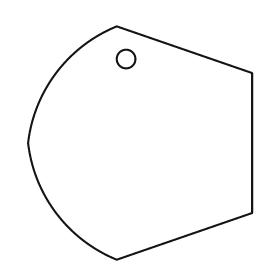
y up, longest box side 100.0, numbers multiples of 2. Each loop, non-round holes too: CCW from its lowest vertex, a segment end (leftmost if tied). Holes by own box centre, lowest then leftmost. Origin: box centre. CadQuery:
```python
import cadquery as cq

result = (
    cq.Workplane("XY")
    .moveTo(-10.0, -50.0)
    .lineTo(48.0, -30.0)
    .lineTo(48.0, 30.0)
    .lineTo(-10.0, 50.0)
    .threePointArc((-36.0, 30.0), (-48.0, 0.0))
    .threePointArc((-36.0, -30.0), (-10.0, -50.0))
    .close()
    .moveTo(-6.0, 36.0)
    .circle(4.0)
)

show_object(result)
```